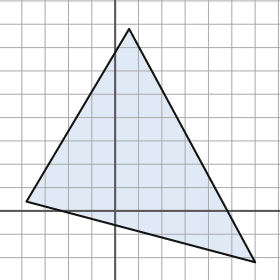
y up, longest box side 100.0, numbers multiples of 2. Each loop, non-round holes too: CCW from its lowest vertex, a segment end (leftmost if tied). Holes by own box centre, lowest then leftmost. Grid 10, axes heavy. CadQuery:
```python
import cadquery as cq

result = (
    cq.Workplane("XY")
    .moveTo(60.0, -22.0)
    .lineTo(6.0, 78.0)
    .lineTo(-38.0, 4.0)
    .close()
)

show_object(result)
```